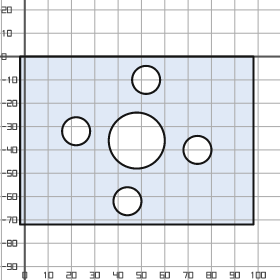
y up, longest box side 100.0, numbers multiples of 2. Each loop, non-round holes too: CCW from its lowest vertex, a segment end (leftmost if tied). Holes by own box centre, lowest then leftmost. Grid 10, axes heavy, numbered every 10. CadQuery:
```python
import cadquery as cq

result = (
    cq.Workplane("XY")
    .moveTo(-2.0, -72.0)
    .lineTo(98.0, -72.0)
    .lineTo(98.0, 0.0)
    .lineTo(-2.0, 0.0)
    .close()
    .moveTo(44.0, -62.0)
    .circle(6.0)
    .moveTo(74.0, -40.0)
    .circle(6.0)
    .moveTo(48.0, -36.0)
    .circle(12.0)
    .moveTo(22.0, -32.0)
    .circle(6.0)
    .moveTo(52.0, -10.0)
    .circle(6.0)
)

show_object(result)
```